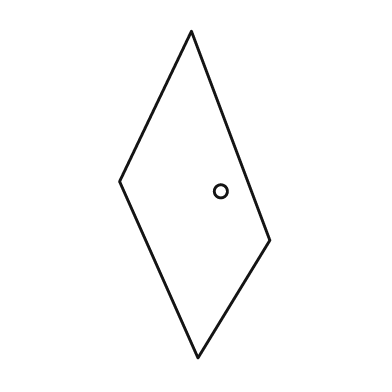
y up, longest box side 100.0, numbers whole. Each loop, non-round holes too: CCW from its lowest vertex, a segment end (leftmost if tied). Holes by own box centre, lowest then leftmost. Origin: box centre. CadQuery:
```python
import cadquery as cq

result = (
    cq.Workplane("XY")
    .moveTo(1.0, -50.0)
    .lineTo(23.0, -14.0)
    .lineTo(-1.0, 50.0)
    .lineTo(-23.0, 4.0)
    .close()
    .moveTo(8.0, 1.0)
    .circle(2.0)
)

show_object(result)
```